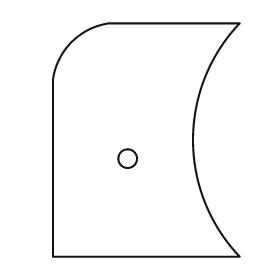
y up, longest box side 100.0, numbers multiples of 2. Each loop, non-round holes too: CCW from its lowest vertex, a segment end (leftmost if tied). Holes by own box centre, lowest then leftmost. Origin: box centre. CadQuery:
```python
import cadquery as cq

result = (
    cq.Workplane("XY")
    .moveTo(-40.0, -50.0)
    .lineTo(40.0, -50.0)
    .threePointArc((20.0, 0.0), (40.0, 50.0))
    .lineTo(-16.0, 50.0)
    .threePointArc((-32.0, 42.0), (-40.0, 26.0))
    .close()
    .moveTo(-8.0, -8.0)
    .circle(4.0)
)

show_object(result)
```